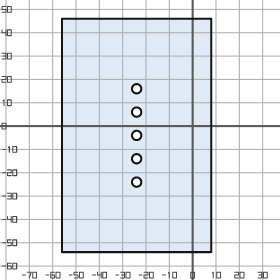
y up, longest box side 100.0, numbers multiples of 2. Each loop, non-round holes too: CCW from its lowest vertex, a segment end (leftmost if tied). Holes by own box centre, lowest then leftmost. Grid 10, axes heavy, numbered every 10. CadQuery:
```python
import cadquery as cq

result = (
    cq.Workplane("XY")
    .moveTo(-56.0, -54.0)
    .lineTo(8.0, -54.0)
    .lineTo(8.0, 46.0)
    .lineTo(-56.0, 46.0)
    .close()
    .moveTo(-24.0, -24.0)
    .circle(2.0)
    .moveTo(-24.0, -14.0)
    .circle(2.0)
    .moveTo(-24.0, -4.0)
    .circle(2.0)
    .moveTo(-24.0, 6.0)
    .circle(2.0)
    .moveTo(-24.0, 16.0)
    .circle(2.0)
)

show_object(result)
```